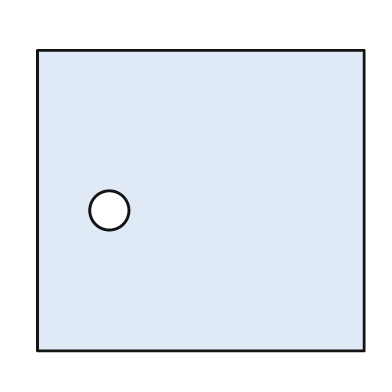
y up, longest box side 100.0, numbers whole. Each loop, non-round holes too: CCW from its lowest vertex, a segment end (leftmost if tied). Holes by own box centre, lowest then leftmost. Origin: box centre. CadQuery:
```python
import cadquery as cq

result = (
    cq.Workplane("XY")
    .moveTo(-50.0, -46.0)
    .lineTo(50.0, -46.0)
    .lineTo(50.0, 46.0)
    .lineTo(-50.0, 46.0)
    .close()
    .moveTo(-28.0, -3.0)
    .circle(6.0)
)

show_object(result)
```